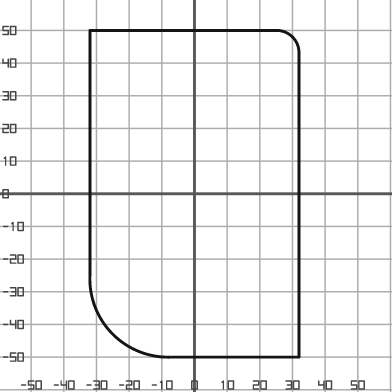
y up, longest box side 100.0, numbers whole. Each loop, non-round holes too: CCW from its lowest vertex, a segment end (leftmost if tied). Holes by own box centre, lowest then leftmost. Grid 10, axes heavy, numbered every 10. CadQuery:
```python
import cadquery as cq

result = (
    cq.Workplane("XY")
    .moveTo(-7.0, -50.0)
    .lineTo(32.0, -50.0)
    .lineTo(32.0, 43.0)
    .threePointArc((30.0, 48.0), (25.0, 50.0))
    .lineTo(-32.0, 50.0)
    .lineTo(-32.0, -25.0)
    .threePointArc((-25.0, -43.0), (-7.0, -50.0))
    .close()
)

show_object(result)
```